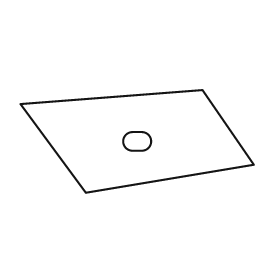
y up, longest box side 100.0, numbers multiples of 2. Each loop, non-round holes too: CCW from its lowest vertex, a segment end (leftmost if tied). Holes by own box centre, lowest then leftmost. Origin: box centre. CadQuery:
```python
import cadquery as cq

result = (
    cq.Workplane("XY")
    .moveTo(-22.0, -22.0)
    .lineTo(50.0, -10.0)
    .lineTo(28.0, 22.0)
    .lineTo(-50.0, 16.0)
    .close()
    .moveTo(-2.0, -4.0)
    .lineTo(2.0, -4.0)
    .threePointArc((6.0, 0.0), (2.0, 4.0))
    .lineTo(-2.0, 4.0)
    .threePointArc((-6.0, 0.0), (-2.0, -4.0))
    .close()
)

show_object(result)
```